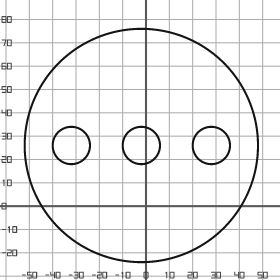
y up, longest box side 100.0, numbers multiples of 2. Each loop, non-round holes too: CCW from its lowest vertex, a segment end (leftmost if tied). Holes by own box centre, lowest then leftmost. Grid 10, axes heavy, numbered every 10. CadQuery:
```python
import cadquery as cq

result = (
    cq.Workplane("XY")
    .moveTo(-2.0, 26.0)
    .circle(50.0)
    .moveTo(-32.0, 26.0)
    .circle(8.0)
    .moveTo(-2.0, 26.0)
    .circle(8.0)
    .moveTo(28.0, 26.0)
    .circle(8.0)
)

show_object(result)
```